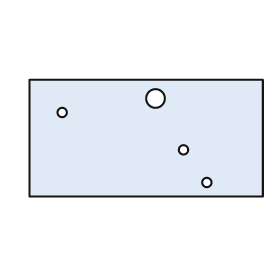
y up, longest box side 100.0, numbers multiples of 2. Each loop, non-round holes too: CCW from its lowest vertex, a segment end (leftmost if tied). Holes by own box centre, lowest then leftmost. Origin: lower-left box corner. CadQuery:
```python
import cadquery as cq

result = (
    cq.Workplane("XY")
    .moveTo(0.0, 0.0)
    .lineTo(100.0, 0.0)
    .lineTo(100.0, 50.0)
    .lineTo(0.0, 50.0)
    .close()
    .moveTo(76.0, 6.0)
    .circle(2.0)
    .moveTo(66.0, 20.0)
    .circle(2.0)
    .moveTo(14.0, 36.0)
    .circle(2.0)
    .moveTo(54.0, 42.0)
    .circle(4.0)
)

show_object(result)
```